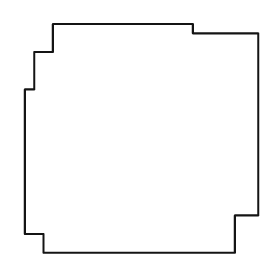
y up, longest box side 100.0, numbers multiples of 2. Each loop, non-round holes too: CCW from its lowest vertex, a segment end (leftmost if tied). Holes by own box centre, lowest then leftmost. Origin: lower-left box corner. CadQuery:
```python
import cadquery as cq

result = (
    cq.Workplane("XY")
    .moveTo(8.0, 0.0)
    .lineTo(90.0, 0.0)
    .lineTo(90.0, 16.0)
    .lineTo(100.0, 16.0)
    .lineTo(100.0, 94.0)
    .lineTo(72.0, 94.0)
    .lineTo(72.0, 98.0)
    .lineTo(12.0, 98.0)
    .lineTo(12.0, 86.0)
    .lineTo(4.0, 86.0)
    .lineTo(4.0, 70.0)
    .lineTo(0.0, 70.0)
    .lineTo(0.0, 8.0)
    .lineTo(8.0, 8.0)
    .close()
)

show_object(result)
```